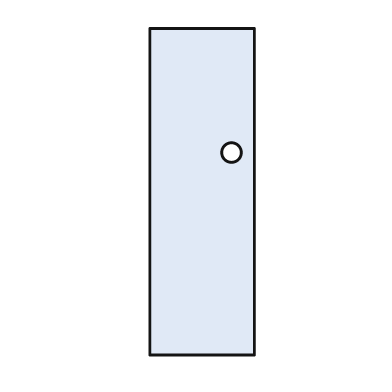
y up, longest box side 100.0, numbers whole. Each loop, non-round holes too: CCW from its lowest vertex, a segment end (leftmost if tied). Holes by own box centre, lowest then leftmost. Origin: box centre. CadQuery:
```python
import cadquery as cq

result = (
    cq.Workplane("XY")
    .moveTo(-16.0, -50.0)
    .lineTo(16.0, -50.0)
    .lineTo(16.0, 50.0)
    .lineTo(-16.0, 50.0)
    .close()
    .moveTo(9.0, 12.0)
    .circle(3.0)
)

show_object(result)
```